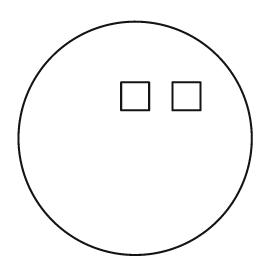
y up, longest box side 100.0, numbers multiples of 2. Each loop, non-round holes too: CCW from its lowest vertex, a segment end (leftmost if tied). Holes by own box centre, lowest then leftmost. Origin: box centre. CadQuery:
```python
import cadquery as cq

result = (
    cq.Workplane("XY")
    .moveTo(0.0, 0.0)
    .circle(50.0)
    .moveTo(-6.0, 12.0)
    .lineTo(6.0, 12.0)
    .lineTo(6.0, 24.0)
    .lineTo(-6.0, 24.0)
    .close()
    .moveTo(16.0, 12.0)
    .lineTo(28.0, 12.0)
    .lineTo(28.0, 24.0)
    .lineTo(16.0, 24.0)
    .close()
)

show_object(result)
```